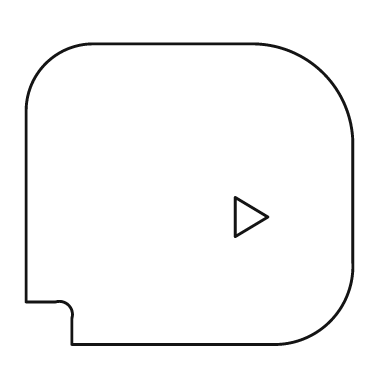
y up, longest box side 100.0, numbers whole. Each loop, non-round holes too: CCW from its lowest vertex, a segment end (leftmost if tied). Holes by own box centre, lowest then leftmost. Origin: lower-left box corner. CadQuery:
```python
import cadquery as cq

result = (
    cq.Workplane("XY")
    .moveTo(14.0, 0.0)
    .lineTo(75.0, 0.0)
    .threePointArc((93.0, 7.0), (100.0, 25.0))
    .lineTo(100.0, 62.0)
    .threePointArc((91.0, 83.0), (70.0, 92.0))
    .lineTo(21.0, 92.0)
    .threePointArc((6.0, 86.0), (0.0, 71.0))
    .lineTo(0.0, 13.0)
    .lineTo(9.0, 13.0)
    .threePointArc((13.0, 12.0), (14.0, 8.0))
    .close()
    .moveTo(64.0, 33.0)
    .lineTo(74.0, 39.0)
    .lineTo(64.0, 45.0)
    .close()
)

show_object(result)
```